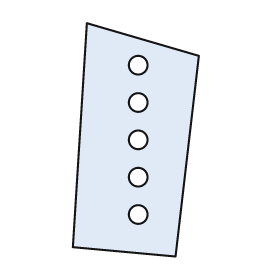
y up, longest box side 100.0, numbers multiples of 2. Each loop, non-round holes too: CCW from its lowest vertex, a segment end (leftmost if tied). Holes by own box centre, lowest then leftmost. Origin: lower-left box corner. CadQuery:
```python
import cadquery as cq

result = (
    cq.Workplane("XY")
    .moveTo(44.0, 0.0)
    .lineTo(54.0, 86.0)
    .lineTo(6.0, 100.0)
    .lineTo(0.0, 4.0)
    .close()
    .moveTo(28.0, 18.0)
    .circle(4.0)
    .moveTo(28.0, 34.0)
    .circle(4.0)
    .moveTo(28.0, 50.0)
    .circle(4.0)
    .moveTo(28.0, 66.0)
    .circle(4.0)
    .moveTo(28.0, 82.0)
    .circle(4.0)
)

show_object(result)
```